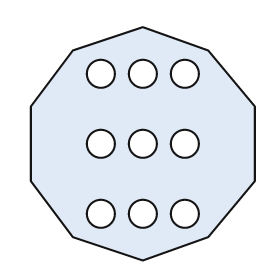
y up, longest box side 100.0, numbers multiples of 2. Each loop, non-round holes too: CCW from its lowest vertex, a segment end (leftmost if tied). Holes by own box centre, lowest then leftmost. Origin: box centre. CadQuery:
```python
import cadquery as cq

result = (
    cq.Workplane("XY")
    .moveTo(0.0, -50.0)
    .lineTo(28.0, -40.0)
    .lineTo(48.0, -16.0)
    .lineTo(48.0, 16.0)
    .lineTo(28.0, 40.0)
    .lineTo(0.0, 50.0)
    .lineTo(-30.0, 40.0)
    .lineTo(-48.0, 16.0)
    .lineTo(-48.0, -16.0)
    .lineTo(-30.0, -40.0)
    .close()
    .moveTo(-18.0, -30.0)
    .circle(6.0)
    .moveTo(0.0, -30.0)
    .circle(6.0)
    .moveTo(18.0, -30.0)
    .circle(6.0)
    .moveTo(-18.0, 0.0)
    .circle(6.0)
    .moveTo(0.0, 0.0)
    .circle(6.0)
    .moveTo(18.0, 0.0)
    .circle(6.0)
    .moveTo(-18.0, 30.0)
    .circle(6.0)
    .moveTo(0.0, 30.0)
    .circle(6.0)
    .moveTo(18.0, 30.0)
    .circle(6.0)
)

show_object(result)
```